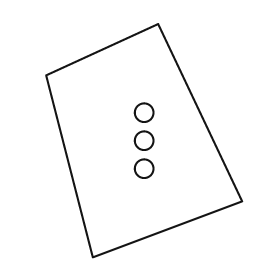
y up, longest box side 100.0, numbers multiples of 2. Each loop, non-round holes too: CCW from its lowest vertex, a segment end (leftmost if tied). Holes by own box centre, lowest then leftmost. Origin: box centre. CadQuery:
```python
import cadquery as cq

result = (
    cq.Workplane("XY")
    .moveTo(-22.0, -50.0)
    .lineTo(42.0, -26.0)
    .lineTo(6.0, 50.0)
    .lineTo(-42.0, 28.0)
    .close()
    .moveTo(0.0, -12.0)
    .circle(4.0)
    .moveTo(0.0, 0.0)
    .circle(4.0)
    .moveTo(0.0, 12.0)
    .circle(4.0)
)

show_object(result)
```